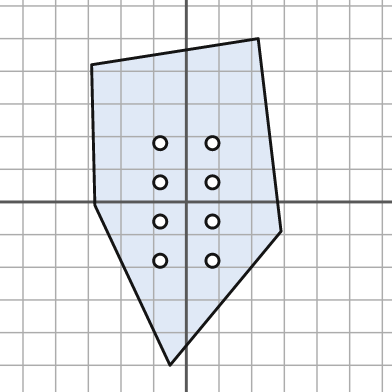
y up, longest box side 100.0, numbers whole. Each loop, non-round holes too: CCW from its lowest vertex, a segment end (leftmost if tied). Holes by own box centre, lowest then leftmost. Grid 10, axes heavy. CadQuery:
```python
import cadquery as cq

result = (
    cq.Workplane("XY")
    .moveTo(-5.0, -50.0)
    .lineTo(29.0, -9.0)
    .lineTo(22.0, 50.0)
    .lineTo(-29.0, 42.0)
    .lineTo(-28.0, -1.0)
    .close()
    .moveTo(-8.0, -18.0)
    .circle(2.0)
    .moveTo(8.0, -18.0)
    .circle(2.0)
    .moveTo(-8.0, -6.0)
    .circle(2.0)
    .moveTo(8.0, -6.0)
    .circle(2.0)
    .moveTo(-8.0, 6.0)
    .circle(2.0)
    .moveTo(8.0, 6.0)
    .circle(2.0)
    .moveTo(-8.0, 18.0)
    .circle(2.0)
    .moveTo(8.0, 18.0)
    .circle(2.0)
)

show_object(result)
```